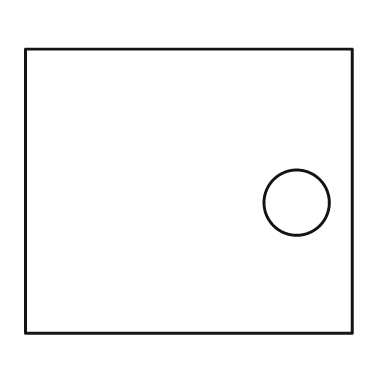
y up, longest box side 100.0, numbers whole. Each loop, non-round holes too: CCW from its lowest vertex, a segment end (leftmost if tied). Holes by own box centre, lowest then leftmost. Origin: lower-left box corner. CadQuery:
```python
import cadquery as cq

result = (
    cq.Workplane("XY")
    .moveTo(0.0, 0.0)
    .lineTo(100.0, 0.0)
    .lineTo(100.0, 87.0)
    .lineTo(0.0, 87.0)
    .close()
    .moveTo(83.0, 40.0)
    .circle(10.0)
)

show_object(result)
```